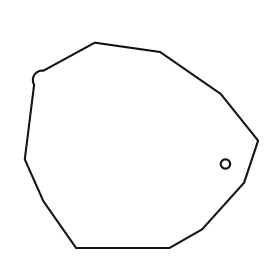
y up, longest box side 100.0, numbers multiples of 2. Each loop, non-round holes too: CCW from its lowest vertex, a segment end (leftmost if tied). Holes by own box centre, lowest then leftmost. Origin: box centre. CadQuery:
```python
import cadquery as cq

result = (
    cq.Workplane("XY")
    .moveTo(-28.0, -44.0)
    .lineTo(12.0, -44.0)
    .lineTo(26.0, -36.0)
    .lineTo(44.0, -16.0)
    .lineTo(50.0, 2.0)
    .lineTo(34.0, 22.0)
    .lineTo(8.0, 40.0)
    .lineTo(-20.0, 44.0)
    .lineTo(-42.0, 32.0)
    .threePointArc((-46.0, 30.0), (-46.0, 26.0))
    .lineTo(-50.0, -6.0)
    .lineTo(-42.0, -24.0)
    .close()
    .moveTo(36.0, -8.0)
    .circle(2.0)
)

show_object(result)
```